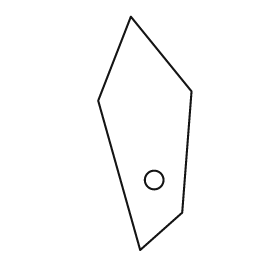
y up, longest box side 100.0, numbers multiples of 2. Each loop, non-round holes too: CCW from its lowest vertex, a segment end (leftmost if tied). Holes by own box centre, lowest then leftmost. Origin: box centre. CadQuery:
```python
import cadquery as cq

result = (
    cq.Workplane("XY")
    .moveTo(-2.0, -50.0)
    .lineTo(16.0, -34.0)
    .lineTo(20.0, 18.0)
    .lineTo(-6.0, 50.0)
    .lineTo(-20.0, 14.0)
    .close()
    .moveTo(4.0, -20.0)
    .circle(4.0)
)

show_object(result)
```